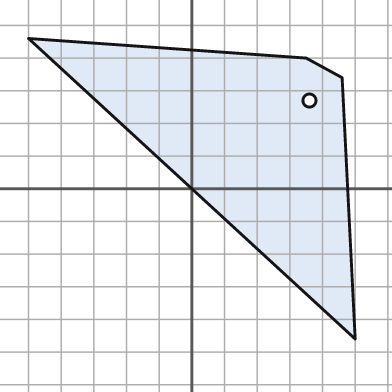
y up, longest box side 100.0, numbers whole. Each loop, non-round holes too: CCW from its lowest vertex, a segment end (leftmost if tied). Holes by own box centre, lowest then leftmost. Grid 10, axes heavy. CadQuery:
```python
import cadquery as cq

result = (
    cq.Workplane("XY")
    .moveTo(50.0, -46.0)
    .lineTo(46.0, 34.0)
    .lineTo(35.0, 40.0)
    .lineTo(-50.0, 46.0)
    .close()
    .moveTo(36.0, 27.0)
    .circle(2.0)
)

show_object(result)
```